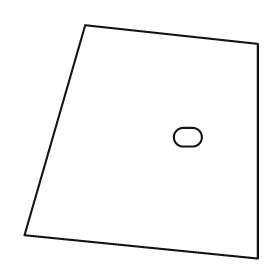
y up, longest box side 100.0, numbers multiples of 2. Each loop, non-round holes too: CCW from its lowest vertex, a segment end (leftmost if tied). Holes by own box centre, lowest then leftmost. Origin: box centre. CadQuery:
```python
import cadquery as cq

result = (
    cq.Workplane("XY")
    .moveTo(50.0, -50.0)
    .lineTo(50.0, 42.0)
    .lineTo(-24.0, 50.0)
    .lineTo(-50.0, -40.0)
    .close()
    .moveTo(18.0, -2.0)
    .lineTo(22.0, -2.0)
    .threePointArc((26.0, 2.0), (22.0, 6.0))
    .lineTo(18.0, 6.0)
    .threePointArc((14.0, 2.0), (18.0, -2.0))
    .close()
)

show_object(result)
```